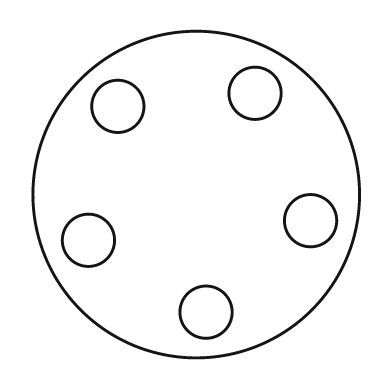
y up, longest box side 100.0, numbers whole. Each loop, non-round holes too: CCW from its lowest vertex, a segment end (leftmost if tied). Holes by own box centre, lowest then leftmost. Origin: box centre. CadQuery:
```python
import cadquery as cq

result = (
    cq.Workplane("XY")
    .moveTo(0.0, 0.0)
    .circle(50.0)
    .moveTo(3.0, -36.0)
    .circle(8.0)
    .moveTo(-33.0, -14.0)
    .circle(8.0)
    .moveTo(35.0, -8.0)
    .circle(8.0)
    .moveTo(-24.0, 27.0)
    .circle(8.0)
    .moveTo(18.0, 31.0)
    .circle(8.0)
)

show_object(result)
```